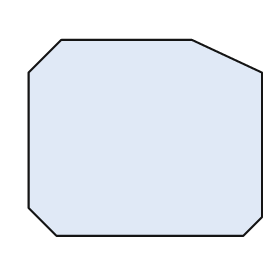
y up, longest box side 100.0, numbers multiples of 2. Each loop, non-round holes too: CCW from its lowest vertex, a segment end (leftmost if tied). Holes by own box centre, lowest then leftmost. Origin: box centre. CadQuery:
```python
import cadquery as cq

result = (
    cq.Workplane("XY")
    .moveTo(-38.0, -42.0)
    .lineTo(42.0, -42.0)
    .lineTo(50.0, -34.0)
    .lineTo(50.0, 28.0)
    .lineTo(20.0, 42.0)
    .lineTo(-36.0, 42.0)
    .lineTo(-50.0, 28.0)
    .lineTo(-50.0, -30.0)
    .close()
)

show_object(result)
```